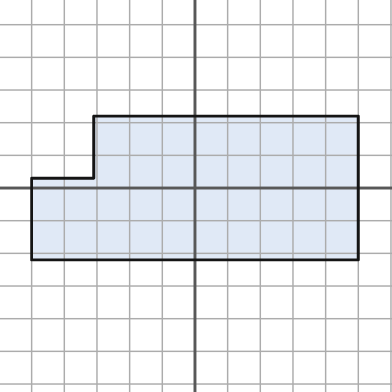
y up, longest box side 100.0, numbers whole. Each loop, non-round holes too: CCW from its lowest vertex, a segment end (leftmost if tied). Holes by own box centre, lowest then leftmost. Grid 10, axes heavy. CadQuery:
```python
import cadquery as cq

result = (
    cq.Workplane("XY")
    .moveTo(-50.0, -22.0)
    .lineTo(50.0, -22.0)
    .lineTo(50.0, 22.0)
    .lineTo(-31.0, 22.0)
    .lineTo(-31.0, 3.0)
    .lineTo(-50.0, 3.0)
    .close()
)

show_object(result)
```